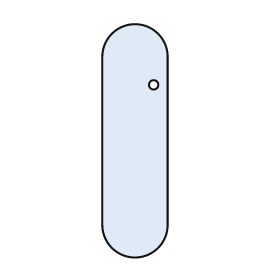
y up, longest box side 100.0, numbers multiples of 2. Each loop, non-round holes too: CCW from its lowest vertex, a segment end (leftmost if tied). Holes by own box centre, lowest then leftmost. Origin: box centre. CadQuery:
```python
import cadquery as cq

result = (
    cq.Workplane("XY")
    .moveTo(-14.0, -36.0)
    .threePointArc((0.0, -50.0), (14.0, -36.0))
    .lineTo(14.0, 36.0)
    .threePointArc((0.0, 50.0), (-14.0, 36.0))
    .close()
    .moveTo(8.0, 24.0)
    .circle(2.0)
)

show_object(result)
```